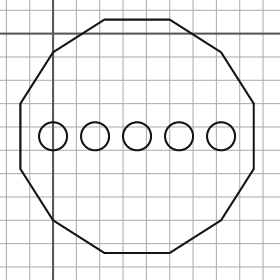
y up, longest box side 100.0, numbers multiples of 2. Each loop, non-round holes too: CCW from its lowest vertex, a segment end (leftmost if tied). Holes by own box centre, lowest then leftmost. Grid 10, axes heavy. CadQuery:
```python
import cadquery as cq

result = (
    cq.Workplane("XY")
    .moveTo(22.0, -94.0)
    .lineTo(50.0, -94.0)
    .lineTo(72.0, -80.0)
    .lineTo(86.0, -58.0)
    .lineTo(86.0, -30.0)
    .lineTo(72.0, -8.0)
    .lineTo(50.0, 6.0)
    .lineTo(22.0, 6.0)
    .lineTo(0.0, -8.0)
    .lineTo(-14.0, -30.0)
    .lineTo(-14.0, -58.0)
    .lineTo(0.0, -80.0)
    .close()
    .moveTo(0.0, -44.0)
    .circle(6.0)
    .moveTo(18.0, -44.0)
    .circle(6.0)
    .moveTo(36.0, -44.0)
    .circle(6.0)
    .moveTo(54.0, -44.0)
    .circle(6.0)
    .moveTo(72.0, -44.0)
    .circle(6.0)
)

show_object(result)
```